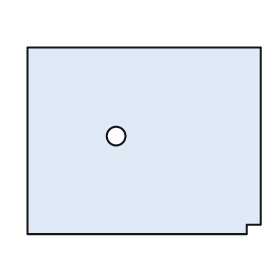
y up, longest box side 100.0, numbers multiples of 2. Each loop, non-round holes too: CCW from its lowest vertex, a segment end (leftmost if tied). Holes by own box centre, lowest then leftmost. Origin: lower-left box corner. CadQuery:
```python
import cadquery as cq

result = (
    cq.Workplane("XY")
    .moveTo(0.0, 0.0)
    .lineTo(94.0, 0.0)
    .lineTo(94.0, 4.0)
    .lineTo(100.0, 4.0)
    .lineTo(100.0, 80.0)
    .lineTo(0.0, 80.0)
    .close()
    .moveTo(38.0, 42.0)
    .circle(4.0)
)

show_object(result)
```